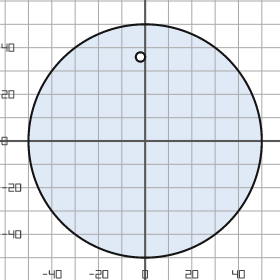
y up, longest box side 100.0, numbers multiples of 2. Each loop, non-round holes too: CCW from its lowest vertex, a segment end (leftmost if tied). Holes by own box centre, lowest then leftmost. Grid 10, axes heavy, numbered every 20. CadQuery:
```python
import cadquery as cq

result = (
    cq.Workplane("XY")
    .moveTo(0.0, 0.0)
    .circle(50.0)
    .moveTo(-2.0, 36.0)
    .circle(2.0)
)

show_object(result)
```